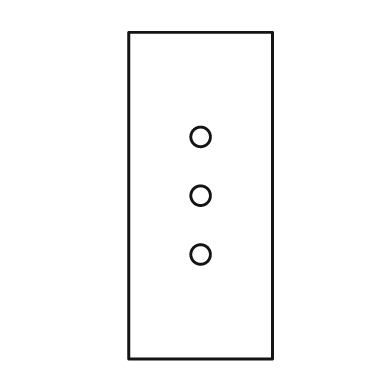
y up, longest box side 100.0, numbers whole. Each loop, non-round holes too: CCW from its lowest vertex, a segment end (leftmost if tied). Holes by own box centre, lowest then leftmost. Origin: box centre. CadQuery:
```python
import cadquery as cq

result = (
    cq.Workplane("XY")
    .moveTo(-22.0, -50.0)
    .lineTo(22.0, -50.0)
    .lineTo(22.0, 50.0)
    .lineTo(-22.0, 50.0)
    .close()
    .moveTo(0.0, -18.0)
    .circle(3.0)
    .moveTo(0.0, 0.0)
    .circle(3.0)
    .moveTo(0.0, 18.0)
    .circle(3.0)
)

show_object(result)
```